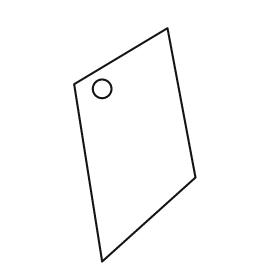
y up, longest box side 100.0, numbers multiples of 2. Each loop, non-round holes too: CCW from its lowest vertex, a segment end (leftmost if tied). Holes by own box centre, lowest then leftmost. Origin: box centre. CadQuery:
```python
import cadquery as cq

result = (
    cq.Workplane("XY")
    .moveTo(-14.0, -50.0)
    .lineTo(26.0, -14.0)
    .lineTo(14.0, 50.0)
    .lineTo(-26.0, 26.0)
    .close()
    .moveTo(-14.0, 24.0)
    .circle(4.0)
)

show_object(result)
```